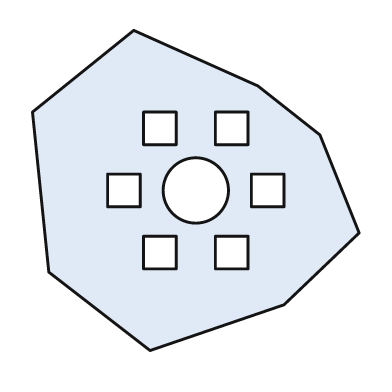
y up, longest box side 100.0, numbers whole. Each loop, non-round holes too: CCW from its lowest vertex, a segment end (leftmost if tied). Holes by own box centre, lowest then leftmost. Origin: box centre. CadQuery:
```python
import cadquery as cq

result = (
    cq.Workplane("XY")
    .moveTo(-14.0, -49.0)
    .lineTo(27.0, -35.0)
    .lineTo(50.0, -13.0)
    .lineTo(38.0, 17.0)
    .lineTo(19.0, 32.0)
    .lineTo(-19.0, 49.0)
    .lineTo(-50.0, 24.0)
    .lineTo(-45.0, -25.0)
    .close()
    .moveTo(-16.0, -24.0)
    .lineTo(-6.0, -24.0)
    .lineTo(-6.0, -14.0)
    .lineTo(-16.0, -14.0)
    .close()
    .moveTo(6.0, -24.0)
    .lineTo(16.0, -24.0)
    .lineTo(16.0, -14.0)
    .lineTo(6.0, -14.0)
    .close()
    .moveTo(-27.0, -5.0)
    .lineTo(-17.0, -5.0)
    .lineTo(-17.0, 5.0)
    .lineTo(-27.0, 5.0)
    .close()
    .moveTo(0.0, 0.0)
    .circle(10.0)
    .moveTo(17.0, -5.0)
    .lineTo(27.0, -5.0)
    .lineTo(27.0, 5.0)
    .lineTo(17.0, 5.0)
    .close()
    .moveTo(-16.0, 14.0)
    .lineTo(-6.0, 14.0)
    .lineTo(-6.0, 24.0)
    .lineTo(-16.0, 24.0)
    .close()
    .moveTo(6.0, 14.0)
    .lineTo(16.0, 14.0)
    .lineTo(16.0, 24.0)
    .lineTo(6.0, 24.0)
    .close()
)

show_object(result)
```